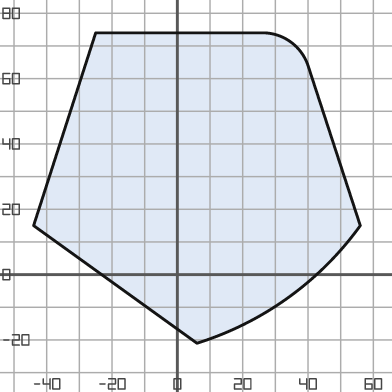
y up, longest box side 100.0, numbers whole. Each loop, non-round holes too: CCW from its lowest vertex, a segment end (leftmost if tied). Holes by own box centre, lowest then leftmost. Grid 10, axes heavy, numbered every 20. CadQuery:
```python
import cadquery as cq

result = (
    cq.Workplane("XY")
    .moveTo(6.0, -21.0)
    .threePointArc((34.0, -7.0), (56.0, 15.0))
    .lineTo(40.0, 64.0)
    .threePointArc((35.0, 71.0), (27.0, 74.0))
    .lineTo(-25.0, 74.0)
    .lineTo(-44.0, 15.0)
    .close()
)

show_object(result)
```